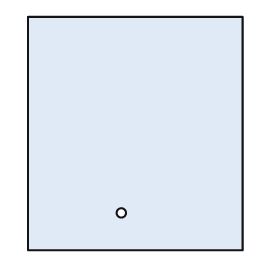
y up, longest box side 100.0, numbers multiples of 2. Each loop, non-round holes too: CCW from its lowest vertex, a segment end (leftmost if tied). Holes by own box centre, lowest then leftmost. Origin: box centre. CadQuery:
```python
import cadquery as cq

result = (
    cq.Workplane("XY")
    .moveTo(-46.0, -50.0)
    .lineTo(46.0, -50.0)
    .lineTo(46.0, 50.0)
    .lineTo(-46.0, 50.0)
    .close()
    .moveTo(-6.0, -34.0)
    .circle(2.0)
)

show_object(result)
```